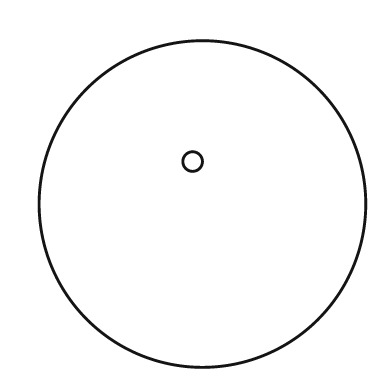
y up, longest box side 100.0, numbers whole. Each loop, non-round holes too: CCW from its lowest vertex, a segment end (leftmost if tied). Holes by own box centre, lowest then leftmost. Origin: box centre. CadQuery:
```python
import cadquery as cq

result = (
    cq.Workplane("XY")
    .moveTo(0.0, 0.0)
    .circle(50.0)
    .moveTo(-3.0, 13.0)
    .circle(3.0)
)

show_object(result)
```